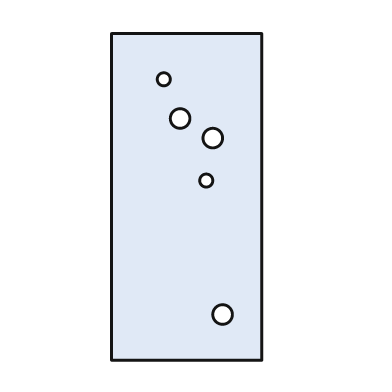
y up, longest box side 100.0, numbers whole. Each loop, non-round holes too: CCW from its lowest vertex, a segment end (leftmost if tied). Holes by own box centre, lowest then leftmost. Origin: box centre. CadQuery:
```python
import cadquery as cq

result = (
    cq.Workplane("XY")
    .moveTo(-23.0, -50.0)
    .lineTo(23.0, -50.0)
    .lineTo(23.0, 50.0)
    .lineTo(-23.0, 50.0)
    .close()
    .moveTo(11.0, -36.0)
    .circle(3.0)
    .moveTo(6.0, 5.0)
    .circle(2.0)
    .moveTo(8.0, 18.0)
    .circle(3.0)
    .moveTo(-2.0, 24.0)
    .circle(3.0)
    .moveTo(-7.0, 36.0)
    .circle(2.0)
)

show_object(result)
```